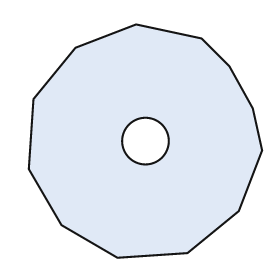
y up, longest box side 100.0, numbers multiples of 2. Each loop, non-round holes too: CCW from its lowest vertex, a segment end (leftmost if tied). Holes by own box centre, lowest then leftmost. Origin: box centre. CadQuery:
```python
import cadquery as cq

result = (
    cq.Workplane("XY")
    .moveTo(-12.0, -50.0)
    .lineTo(18.0, -48.0)
    .lineTo(40.0, -30.0)
    .lineTo(50.0, -4.0)
    .lineTo(46.0, 14.0)
    .lineTo(36.0, 32.0)
    .lineTo(24.0, 44.0)
    .lineTo(-4.0, 50.0)
    .lineTo(-30.0, 40.0)
    .lineTo(-48.0, 18.0)
    .lineTo(-50.0, -12.0)
    .lineTo(-36.0, -36.0)
    .close()
    .moveTo(0.0, 0.0)
    .circle(10.0)
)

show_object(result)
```